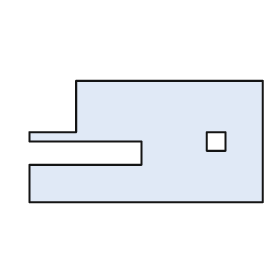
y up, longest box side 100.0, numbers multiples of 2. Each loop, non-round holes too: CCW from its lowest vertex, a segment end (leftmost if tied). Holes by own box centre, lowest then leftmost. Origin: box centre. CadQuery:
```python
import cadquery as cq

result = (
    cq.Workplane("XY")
    .moveTo(-50.0, -26.0)
    .lineTo(50.0, -26.0)
    .lineTo(50.0, 26.0)
    .lineTo(-30.0, 26.0)
    .lineTo(-30.0, 4.0)
    .lineTo(-50.0, 4.0)
    .lineTo(-50.0, 0.0)
    .lineTo(-2.0, 0.0)
    .lineTo(-2.0, -10.0)
    .lineTo(-50.0, -10.0)
    .close()
    .moveTo(26.0, -4.0)
    .lineTo(34.0, -4.0)
    .lineTo(34.0, 4.0)
    .lineTo(26.0, 4.0)
    .close()
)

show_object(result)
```